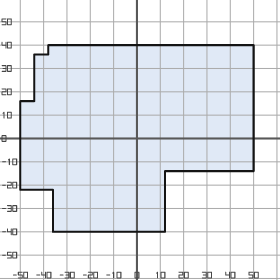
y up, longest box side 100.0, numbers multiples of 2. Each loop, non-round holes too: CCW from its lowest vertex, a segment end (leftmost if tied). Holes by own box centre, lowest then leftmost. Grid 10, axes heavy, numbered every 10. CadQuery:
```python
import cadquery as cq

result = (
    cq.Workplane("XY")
    .moveTo(-36.0, -40.0)
    .lineTo(12.0, -40.0)
    .lineTo(12.0, -14.0)
    .lineTo(50.0, -14.0)
    .lineTo(50.0, 40.0)
    .lineTo(-38.0, 40.0)
    .lineTo(-38.0, 36.0)
    .lineTo(-44.0, 36.0)
    .lineTo(-44.0, 16.0)
    .lineTo(-50.0, 16.0)
    .lineTo(-50.0, -22.0)
    .lineTo(-36.0, -22.0)
    .close()
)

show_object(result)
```